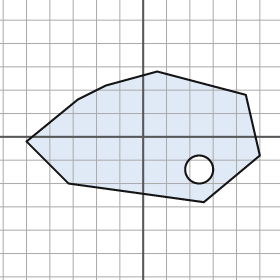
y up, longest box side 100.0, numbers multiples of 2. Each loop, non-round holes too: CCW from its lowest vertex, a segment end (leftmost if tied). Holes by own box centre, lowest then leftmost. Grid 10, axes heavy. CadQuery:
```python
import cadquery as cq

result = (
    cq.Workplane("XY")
    .moveTo(26.0, -28.0)
    .lineTo(50.0, -8.0)
    .lineTo(44.0, 18.0)
    .lineTo(6.0, 28.0)
    .lineTo(-16.0, 22.0)
    .lineTo(-28.0, 16.0)
    .lineTo(-50.0, -2.0)
    .lineTo(-32.0, -20.0)
    .close()
    .moveTo(24.0, -14.0)
    .circle(6.0)
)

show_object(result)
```